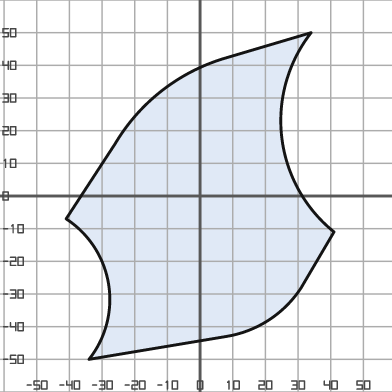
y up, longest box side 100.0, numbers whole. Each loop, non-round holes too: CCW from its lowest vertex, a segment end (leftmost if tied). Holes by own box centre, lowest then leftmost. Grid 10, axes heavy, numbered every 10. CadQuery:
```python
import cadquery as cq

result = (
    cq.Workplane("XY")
    .moveTo(-34.0, -50.0)
    .lineTo(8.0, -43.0)
    .threePointArc((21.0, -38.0), (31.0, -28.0))
    .lineTo(41.0, -11.0)
    .threePointArc((25.0, 18.0), (34.0, 50.0))
    .lineTo(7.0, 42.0)
    .threePointArc((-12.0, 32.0), (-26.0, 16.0))
    .lineTo(-41.0, -7.0)
    .threePointArc((-28.0, -27.0), (-34.0, -50.0))
    .close()
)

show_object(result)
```